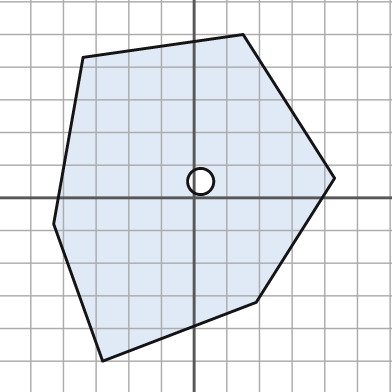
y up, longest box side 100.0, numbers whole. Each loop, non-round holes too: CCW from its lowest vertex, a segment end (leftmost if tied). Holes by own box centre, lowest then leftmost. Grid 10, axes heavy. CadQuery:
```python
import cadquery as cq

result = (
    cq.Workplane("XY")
    .moveTo(-28.0, -50.0)
    .lineTo(19.0, -32.0)
    .lineTo(43.0, 6.0)
    .lineTo(15.0, 50.0)
    .lineTo(-34.0, 43.0)
    .lineTo(-43.0, -8.0)
    .close()
    .moveTo(2.0, 5.0)
    .circle(4.0)
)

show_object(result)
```